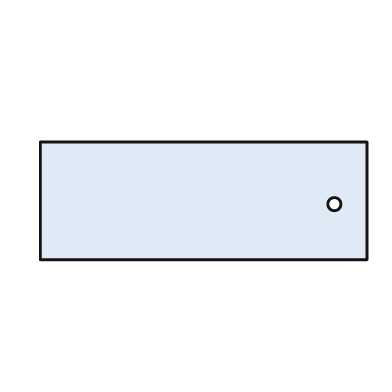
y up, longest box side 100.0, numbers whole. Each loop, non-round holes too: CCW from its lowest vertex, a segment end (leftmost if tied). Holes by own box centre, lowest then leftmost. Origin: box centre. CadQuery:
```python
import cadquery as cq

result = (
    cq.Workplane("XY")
    .moveTo(-50.0, -18.0)
    .lineTo(50.0, -18.0)
    .lineTo(50.0, 18.0)
    .lineTo(-50.0, 18.0)
    .close()
    .moveTo(40.0, -1.0)
    .circle(2.0)
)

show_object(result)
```